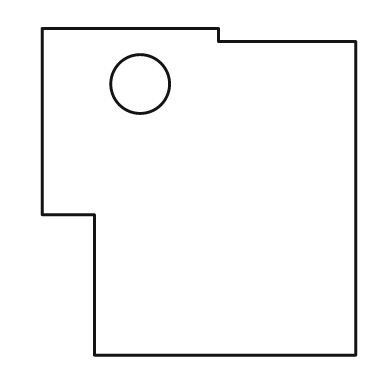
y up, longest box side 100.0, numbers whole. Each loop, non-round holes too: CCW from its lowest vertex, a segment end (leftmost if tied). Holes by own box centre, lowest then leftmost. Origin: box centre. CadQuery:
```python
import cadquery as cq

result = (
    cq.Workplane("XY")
    .moveTo(-32.0, -50.0)
    .lineTo(48.0, -50.0)
    .lineTo(48.0, 46.0)
    .lineTo(6.0, 46.0)
    .lineTo(6.0, 50.0)
    .lineTo(-48.0, 50.0)
    .lineTo(-48.0, -7.0)
    .lineTo(-32.0, -7.0)
    .close()
    .moveTo(-18.0, 33.0)
    .circle(9.0)
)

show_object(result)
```